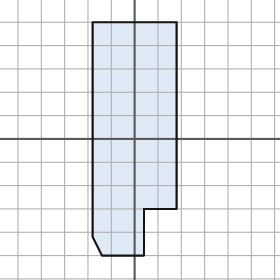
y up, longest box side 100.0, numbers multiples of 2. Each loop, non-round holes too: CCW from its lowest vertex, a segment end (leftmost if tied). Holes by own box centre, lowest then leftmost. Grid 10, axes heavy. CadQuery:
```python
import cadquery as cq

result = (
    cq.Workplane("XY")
    .moveTo(-14.0, -50.0)
    .lineTo(4.0, -50.0)
    .lineTo(4.0, -30.0)
    .lineTo(18.0, -30.0)
    .lineTo(18.0, 50.0)
    .lineTo(-18.0, 50.0)
    .lineTo(-18.0, -42.0)
    .close()
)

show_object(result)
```